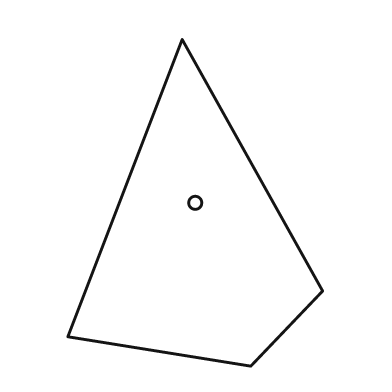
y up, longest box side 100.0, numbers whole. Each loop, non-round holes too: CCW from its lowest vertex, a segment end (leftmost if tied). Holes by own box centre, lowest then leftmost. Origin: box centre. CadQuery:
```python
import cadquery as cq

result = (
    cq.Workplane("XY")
    .moveTo(17.0, -50.0)
    .lineTo(39.0, -27.0)
    .lineTo(-4.0, 50.0)
    .lineTo(-39.0, -41.0)
    .close()
    .moveTo(0.0, 0.0)
    .circle(2.0)
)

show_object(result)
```